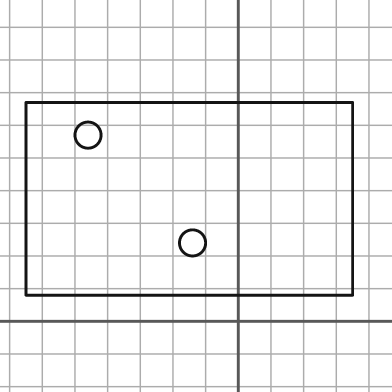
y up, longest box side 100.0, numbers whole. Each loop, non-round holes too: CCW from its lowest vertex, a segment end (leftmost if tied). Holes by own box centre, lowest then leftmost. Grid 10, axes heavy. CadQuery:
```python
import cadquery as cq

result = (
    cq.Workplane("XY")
    .moveTo(-65.0, 8.0)
    .lineTo(35.0, 8.0)
    .lineTo(35.0, 67.0)
    .lineTo(-65.0, 67.0)
    .close()
    .moveTo(-14.0, 24.0)
    .circle(4.0)
    .moveTo(-46.0, 57.0)
    .circle(4.0)
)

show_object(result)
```